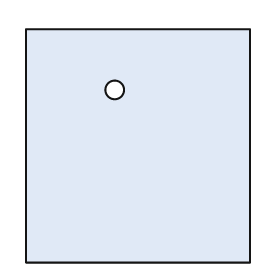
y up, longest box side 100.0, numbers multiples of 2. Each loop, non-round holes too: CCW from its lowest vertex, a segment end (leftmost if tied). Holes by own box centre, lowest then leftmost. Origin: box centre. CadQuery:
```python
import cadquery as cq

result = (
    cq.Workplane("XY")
    .moveTo(-48.0, -50.0)
    .lineTo(48.0, -50.0)
    .lineTo(48.0, 50.0)
    .lineTo(-48.0, 50.0)
    .close()
    .moveTo(-10.0, 24.0)
    .circle(4.0)
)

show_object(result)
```